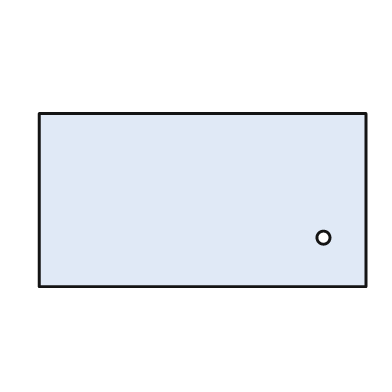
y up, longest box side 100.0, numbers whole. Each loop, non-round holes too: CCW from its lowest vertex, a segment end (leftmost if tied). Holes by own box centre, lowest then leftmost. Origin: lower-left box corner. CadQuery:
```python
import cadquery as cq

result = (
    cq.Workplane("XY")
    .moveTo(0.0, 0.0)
    .lineTo(100.0, 0.0)
    .lineTo(100.0, 53.0)
    .lineTo(0.0, 53.0)
    .close()
    .moveTo(87.0, 15.0)
    .circle(2.0)
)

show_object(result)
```